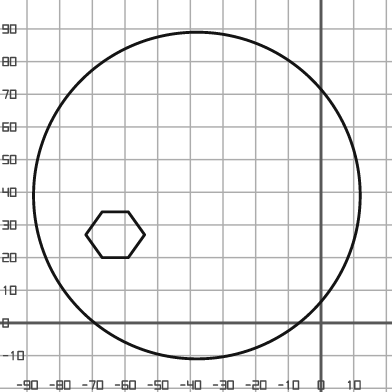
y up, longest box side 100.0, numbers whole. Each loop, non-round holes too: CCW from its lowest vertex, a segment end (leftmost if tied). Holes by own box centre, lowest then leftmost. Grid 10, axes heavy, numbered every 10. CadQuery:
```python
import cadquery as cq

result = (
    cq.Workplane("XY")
    .moveTo(-38.0, 39.0)
    .circle(50.0)
    .moveTo(-67.0, 20.0)
    .lineTo(-59.0, 20.0)
    .lineTo(-54.0, 27.0)
    .lineTo(-59.0, 34.0)
    .lineTo(-67.0, 34.0)
    .lineTo(-72.0, 27.0)
    .close()
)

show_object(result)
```